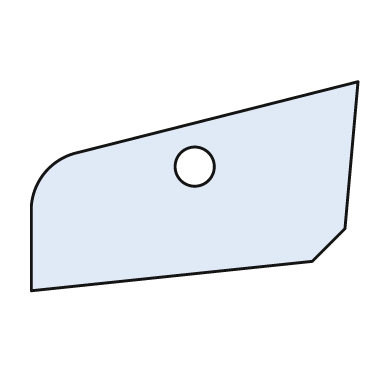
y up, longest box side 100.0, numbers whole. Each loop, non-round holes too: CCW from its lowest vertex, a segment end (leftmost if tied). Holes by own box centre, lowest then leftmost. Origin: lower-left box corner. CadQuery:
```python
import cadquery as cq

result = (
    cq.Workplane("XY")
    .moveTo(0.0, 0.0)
    .lineTo(86.0, 9.0)
    .lineTo(96.0, 19.0)
    .lineTo(100.0, 64.0)
    .lineTo(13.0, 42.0)
    .threePointArc((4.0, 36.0), (0.0, 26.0))
    .close()
    .moveTo(50.0, 38.0)
    .circle(6.0)
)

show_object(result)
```